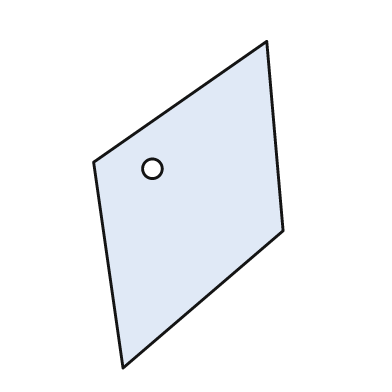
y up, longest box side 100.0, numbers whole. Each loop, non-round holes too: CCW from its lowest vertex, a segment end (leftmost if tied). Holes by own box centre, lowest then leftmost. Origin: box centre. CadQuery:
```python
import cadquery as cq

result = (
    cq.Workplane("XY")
    .moveTo(-20.0, -50.0)
    .lineTo(29.0, -8.0)
    .lineTo(24.0, 50.0)
    .lineTo(-29.0, 13.0)
    .close()
    .moveTo(-11.0, 11.0)
    .circle(3.0)
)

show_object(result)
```